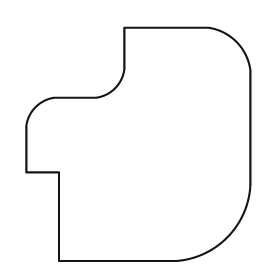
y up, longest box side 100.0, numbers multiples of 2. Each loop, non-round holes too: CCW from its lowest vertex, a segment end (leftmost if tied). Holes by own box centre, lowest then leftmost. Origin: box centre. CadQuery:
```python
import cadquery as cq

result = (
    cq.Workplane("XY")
    .moveTo(-34.0, -50.0)
    .lineTo(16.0, -50.0)
    .threePointArc((38.0, -40.0), (48.0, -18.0))
    .lineTo(48.0, 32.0)
    .threePointArc((42.0, 44.0), (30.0, 50.0))
    .lineTo(-6.0, 50.0)
    .lineTo(-6.0, 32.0)
    .threePointArc((-10.0, 24.0), (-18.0, 20.0))
    .lineTo(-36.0, 20.0)
    .threePointArc((-44.0, 16.0), (-48.0, 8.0))
    .lineTo(-48.0, -12.0)
    .lineTo(-34.0, -12.0)
    .close()
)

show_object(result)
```